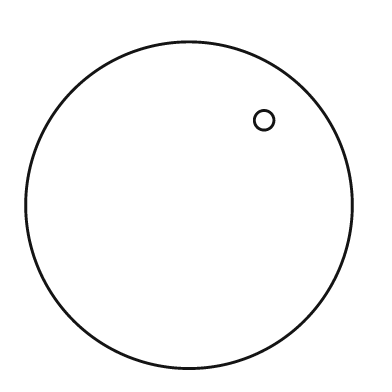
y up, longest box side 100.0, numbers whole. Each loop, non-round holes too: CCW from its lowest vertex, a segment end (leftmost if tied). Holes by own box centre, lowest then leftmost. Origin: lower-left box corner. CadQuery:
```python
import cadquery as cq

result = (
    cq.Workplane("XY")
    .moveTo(50.0, 50.0)
    .circle(50.0)
    .moveTo(73.0, 76.0)
    .circle(3.0)
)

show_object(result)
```